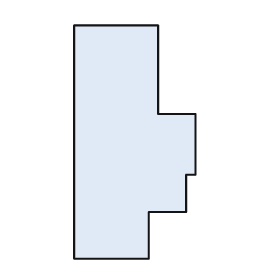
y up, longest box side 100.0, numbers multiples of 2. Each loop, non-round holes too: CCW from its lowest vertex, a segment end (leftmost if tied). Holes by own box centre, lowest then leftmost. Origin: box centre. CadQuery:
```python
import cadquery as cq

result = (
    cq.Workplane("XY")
    .moveTo(-26.0, -50.0)
    .lineTo(6.0, -50.0)
    .lineTo(6.0, -30.0)
    .lineTo(22.0, -30.0)
    .lineTo(22.0, -14.0)
    .lineTo(26.0, -14.0)
    .lineTo(26.0, 12.0)
    .lineTo(10.0, 12.0)
    .lineTo(10.0, 50.0)
    .lineTo(-26.0, 50.0)
    .close()
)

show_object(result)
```